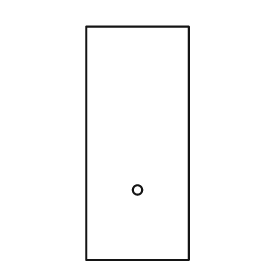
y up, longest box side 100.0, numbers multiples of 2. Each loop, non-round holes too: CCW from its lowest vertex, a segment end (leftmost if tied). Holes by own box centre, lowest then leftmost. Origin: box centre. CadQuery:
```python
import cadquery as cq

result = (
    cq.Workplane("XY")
    .moveTo(-22.0, -50.0)
    .lineTo(22.0, -50.0)
    .lineTo(22.0, 50.0)
    .lineTo(-22.0, 50.0)
    .close()
    .moveTo(0.0, -20.0)
    .circle(2.0)
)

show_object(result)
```